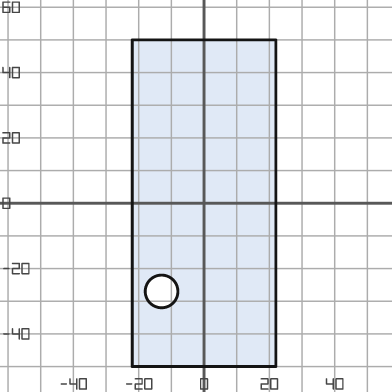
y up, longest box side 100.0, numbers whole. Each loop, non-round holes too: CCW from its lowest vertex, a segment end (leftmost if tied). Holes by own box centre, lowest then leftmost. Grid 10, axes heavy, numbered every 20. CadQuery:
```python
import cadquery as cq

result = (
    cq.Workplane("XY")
    .moveTo(-22.0, -50.0)
    .lineTo(22.0, -50.0)
    .lineTo(22.0, 50.0)
    .lineTo(-22.0, 50.0)
    .close()
    .moveTo(-13.0, -27.0)
    .circle(5.0)
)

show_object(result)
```